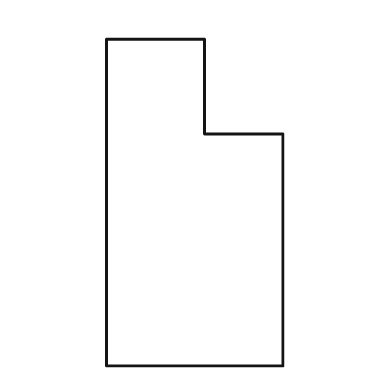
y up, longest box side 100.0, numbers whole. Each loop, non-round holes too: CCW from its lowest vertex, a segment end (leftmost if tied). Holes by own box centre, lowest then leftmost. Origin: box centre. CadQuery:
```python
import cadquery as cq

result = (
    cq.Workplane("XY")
    .moveTo(-27.0, -50.0)
    .lineTo(27.0, -50.0)
    .lineTo(27.0, 21.0)
    .lineTo(3.0, 21.0)
    .lineTo(3.0, 50.0)
    .lineTo(-27.0, 50.0)
    .close()
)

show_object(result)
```